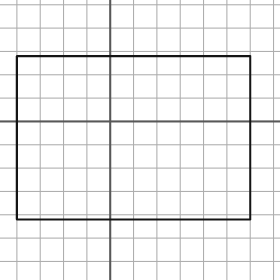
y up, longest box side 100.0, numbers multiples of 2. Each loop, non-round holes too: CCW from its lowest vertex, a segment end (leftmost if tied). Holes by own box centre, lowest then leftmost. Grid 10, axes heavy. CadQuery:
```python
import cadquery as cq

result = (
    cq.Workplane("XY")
    .moveTo(-40.0, -42.0)
    .lineTo(60.0, -42.0)
    .lineTo(60.0, 28.0)
    .lineTo(-40.0, 28.0)
    .close()
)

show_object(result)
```